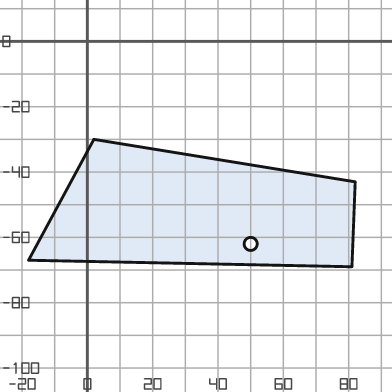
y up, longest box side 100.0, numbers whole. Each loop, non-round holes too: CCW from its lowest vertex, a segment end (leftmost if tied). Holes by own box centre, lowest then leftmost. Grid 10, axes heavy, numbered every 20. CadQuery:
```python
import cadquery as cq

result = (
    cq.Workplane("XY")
    .moveTo(81.0, -69.0)
    .lineTo(82.0, -43.0)
    .lineTo(2.0, -30.0)
    .lineTo(-18.0, -67.0)
    .close()
    .moveTo(50.0, -62.0)
    .circle(2.0)
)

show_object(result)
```